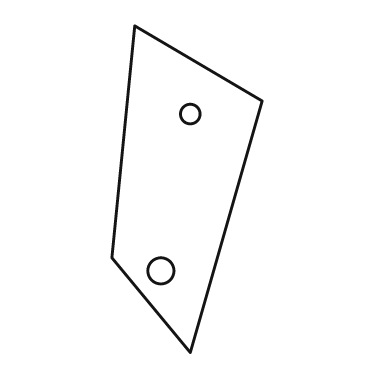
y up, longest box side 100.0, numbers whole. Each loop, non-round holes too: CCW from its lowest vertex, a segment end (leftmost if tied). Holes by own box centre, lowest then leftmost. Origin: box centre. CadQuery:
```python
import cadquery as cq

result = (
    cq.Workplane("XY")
    .moveTo(1.0, -50.0)
    .lineTo(23.0, 27.0)
    .lineTo(-16.0, 50.0)
    .lineTo(-23.0, -21.0)
    .close()
    .moveTo(-8.0, -25.0)
    .circle(4.0)
    .moveTo(1.0, 23.0)
    .circle(3.0)
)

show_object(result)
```